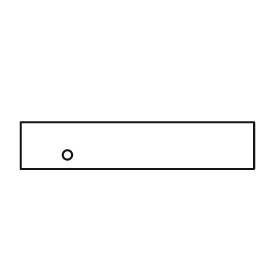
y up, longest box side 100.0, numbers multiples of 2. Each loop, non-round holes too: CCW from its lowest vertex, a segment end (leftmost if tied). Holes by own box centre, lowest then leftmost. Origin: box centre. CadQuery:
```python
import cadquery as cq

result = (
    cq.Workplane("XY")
    .moveTo(-50.0, -10.0)
    .lineTo(50.0, -10.0)
    .lineTo(50.0, 10.0)
    .lineTo(-50.0, 10.0)
    .close()
    .moveTo(-30.0, -4.0)
    .circle(2.0)
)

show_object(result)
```